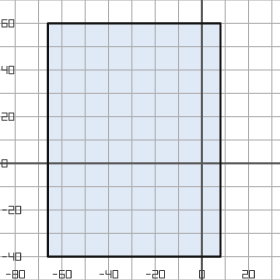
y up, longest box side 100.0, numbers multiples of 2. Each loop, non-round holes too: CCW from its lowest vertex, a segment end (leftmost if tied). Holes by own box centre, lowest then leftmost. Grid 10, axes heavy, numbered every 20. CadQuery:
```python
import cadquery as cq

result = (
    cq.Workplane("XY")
    .moveTo(-66.0, -40.0)
    .lineTo(8.0, -40.0)
    .lineTo(8.0, 60.0)
    .lineTo(-66.0, 60.0)
    .close()
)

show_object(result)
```